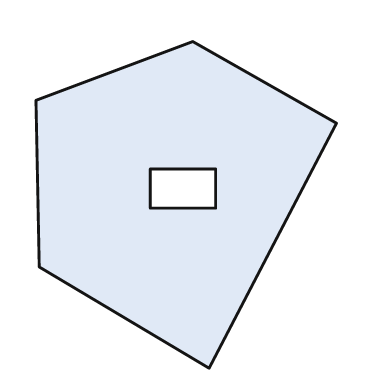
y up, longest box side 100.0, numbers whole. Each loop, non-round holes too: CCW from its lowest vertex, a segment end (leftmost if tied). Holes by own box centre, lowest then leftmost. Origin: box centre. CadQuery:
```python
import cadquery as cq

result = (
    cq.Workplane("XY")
    .moveTo(7.0, -50.0)
    .lineTo(46.0, 25.0)
    .lineTo(2.0, 50.0)
    .lineTo(-46.0, 32.0)
    .lineTo(-45.0, -19.0)
    .close()
    .moveTo(-11.0, -1.0)
    .lineTo(9.0, -1.0)
    .lineTo(9.0, 11.0)
    .lineTo(-11.0, 11.0)
    .close()
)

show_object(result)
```